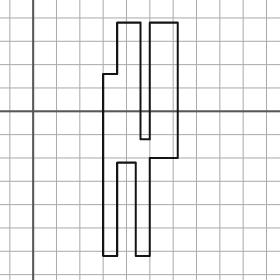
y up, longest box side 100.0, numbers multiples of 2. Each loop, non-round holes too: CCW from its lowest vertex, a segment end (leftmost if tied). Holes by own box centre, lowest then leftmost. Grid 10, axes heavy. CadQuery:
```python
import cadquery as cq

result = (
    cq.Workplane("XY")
    .moveTo(30.0, -62.0)
    .lineTo(36.0, -62.0)
    .lineTo(36.0, -22.0)
    .lineTo(44.0, -22.0)
    .lineTo(44.0, -62.0)
    .lineTo(50.0, -62.0)
    .lineTo(50.0, -20.0)
    .lineTo(62.0, -20.0)
    .lineTo(62.0, 38.0)
    .lineTo(50.0, 38.0)
    .lineTo(50.0, -12.0)
    .lineTo(46.0, -12.0)
    .lineTo(46.0, 38.0)
    .lineTo(36.0, 38.0)
    .lineTo(36.0, 16.0)
    .lineTo(30.0, 16.0)
    .close()
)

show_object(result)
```